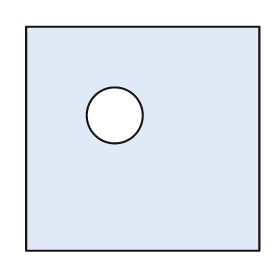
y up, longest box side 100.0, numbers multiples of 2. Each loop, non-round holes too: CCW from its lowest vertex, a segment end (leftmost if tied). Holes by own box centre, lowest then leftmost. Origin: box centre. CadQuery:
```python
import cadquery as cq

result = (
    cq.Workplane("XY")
    .moveTo(-50.0, -48.0)
    .lineTo(50.0, -48.0)
    .lineTo(50.0, 48.0)
    .lineTo(-50.0, 48.0)
    .close()
    .moveTo(-12.0, 10.0)
    .circle(12.0)
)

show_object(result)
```